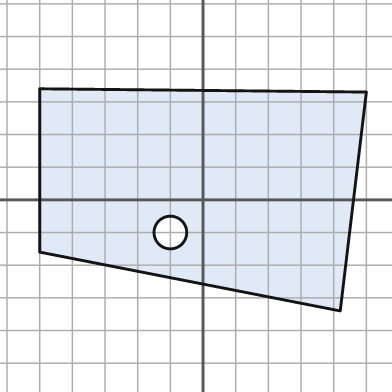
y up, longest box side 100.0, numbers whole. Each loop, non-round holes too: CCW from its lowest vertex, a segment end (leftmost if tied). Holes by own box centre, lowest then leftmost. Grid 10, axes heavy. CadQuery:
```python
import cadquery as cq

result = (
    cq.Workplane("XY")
    .moveTo(42.0, -34.0)
    .lineTo(50.0, 33.0)
    .lineTo(-50.0, 34.0)
    .lineTo(-50.0, -16.0)
    .close()
    .moveTo(-10.0, -10.0)
    .circle(5.0)
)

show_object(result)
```